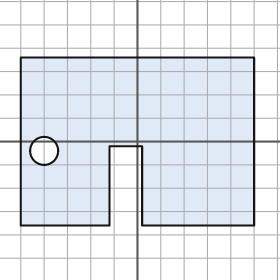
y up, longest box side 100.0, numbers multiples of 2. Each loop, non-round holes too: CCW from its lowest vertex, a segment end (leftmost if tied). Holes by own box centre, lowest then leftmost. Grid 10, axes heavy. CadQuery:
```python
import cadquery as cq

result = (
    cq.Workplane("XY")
    .moveTo(-50.0, -36.0)
    .lineTo(-12.0, -36.0)
    .lineTo(-12.0, -2.0)
    .lineTo(2.0, -2.0)
    .lineTo(2.0, -36.0)
    .lineTo(50.0, -36.0)
    .lineTo(50.0, 36.0)
    .lineTo(-50.0, 36.0)
    .close()
    .moveTo(-40.0, -4.0)
    .circle(6.0)
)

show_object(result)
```